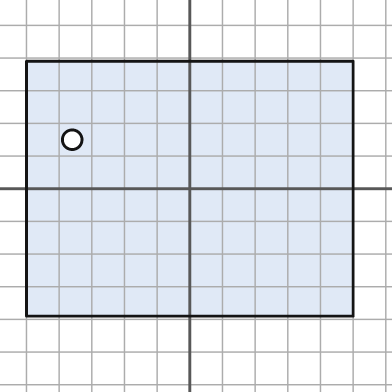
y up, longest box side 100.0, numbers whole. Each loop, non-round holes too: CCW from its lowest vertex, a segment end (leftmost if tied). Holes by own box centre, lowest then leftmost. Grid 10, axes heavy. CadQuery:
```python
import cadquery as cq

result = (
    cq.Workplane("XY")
    .moveTo(-50.0, -39.0)
    .lineTo(50.0, -39.0)
    .lineTo(50.0, 39.0)
    .lineTo(-50.0, 39.0)
    .close()
    .moveTo(-36.0, 15.0)
    .circle(3.0)
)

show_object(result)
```